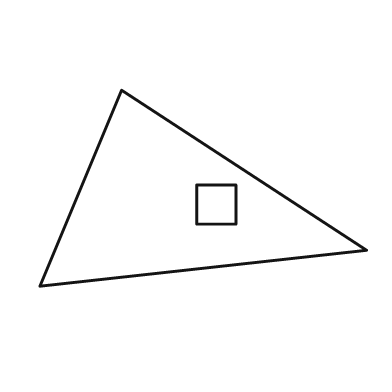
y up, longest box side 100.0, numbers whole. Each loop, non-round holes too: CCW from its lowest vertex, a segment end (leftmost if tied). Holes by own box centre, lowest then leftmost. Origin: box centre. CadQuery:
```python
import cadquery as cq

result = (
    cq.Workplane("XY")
    .moveTo(-50.0, -30.0)
    .lineTo(50.0, -19.0)
    .lineTo(-25.0, 30.0)
    .close()
    .moveTo(-2.0, -11.0)
    .lineTo(10.0, -11.0)
    .lineTo(10.0, 1.0)
    .lineTo(-2.0, 1.0)
    .close()
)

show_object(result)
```